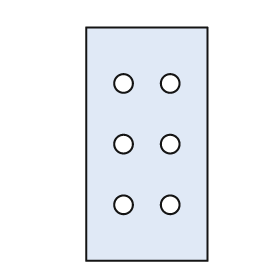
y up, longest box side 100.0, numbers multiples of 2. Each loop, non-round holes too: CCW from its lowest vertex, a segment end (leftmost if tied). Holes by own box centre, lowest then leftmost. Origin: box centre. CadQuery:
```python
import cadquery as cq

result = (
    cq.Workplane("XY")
    .moveTo(-26.0, -50.0)
    .lineTo(26.0, -50.0)
    .lineTo(26.0, 50.0)
    .lineTo(-26.0, 50.0)
    .close()
    .moveTo(-10.0, -26.0)
    .circle(4.0)
    .moveTo(10.0, -26.0)
    .circle(4.0)
    .moveTo(-10.0, 0.0)
    .circle(4.0)
    .moveTo(10.0, 0.0)
    .circle(4.0)
    .moveTo(-10.0, 26.0)
    .circle(4.0)
    .moveTo(10.0, 26.0)
    .circle(4.0)
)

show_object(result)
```